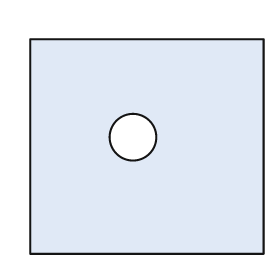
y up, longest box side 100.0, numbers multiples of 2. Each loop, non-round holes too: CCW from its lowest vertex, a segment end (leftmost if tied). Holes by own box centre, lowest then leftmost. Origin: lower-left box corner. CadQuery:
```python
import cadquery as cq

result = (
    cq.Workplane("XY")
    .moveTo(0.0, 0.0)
    .lineTo(100.0, 0.0)
    .lineTo(100.0, 92.0)
    .lineTo(0.0, 92.0)
    .close()
    .moveTo(44.0, 50.0)
    .circle(10.0)
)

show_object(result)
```